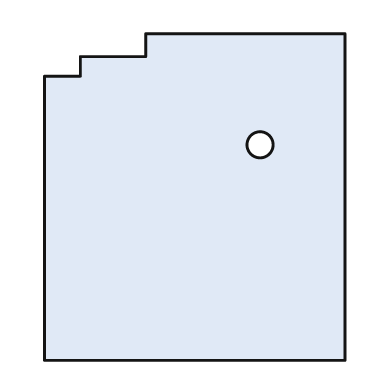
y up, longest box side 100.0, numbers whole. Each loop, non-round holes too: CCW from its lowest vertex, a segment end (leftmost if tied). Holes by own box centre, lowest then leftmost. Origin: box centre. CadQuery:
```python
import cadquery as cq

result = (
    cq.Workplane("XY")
    .moveTo(-46.0, -50.0)
    .lineTo(46.0, -50.0)
    .lineTo(46.0, 50.0)
    .lineTo(-15.0, 50.0)
    .lineTo(-15.0, 43.0)
    .lineTo(-35.0, 43.0)
    .lineTo(-35.0, 37.0)
    .lineTo(-46.0, 37.0)
    .close()
    .moveTo(20.0, 16.0)
    .circle(4.0)
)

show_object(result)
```